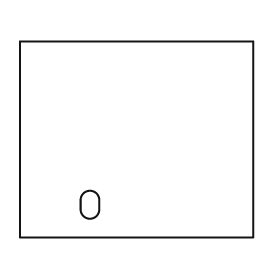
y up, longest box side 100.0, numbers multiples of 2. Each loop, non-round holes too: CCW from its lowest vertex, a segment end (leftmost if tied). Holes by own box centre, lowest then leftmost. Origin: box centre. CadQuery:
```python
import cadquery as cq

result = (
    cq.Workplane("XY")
    .moveTo(-50.0, -42.0)
    .lineTo(50.0, -42.0)
    .lineTo(50.0, 42.0)
    .lineTo(-50.0, 42.0)
    .close()
    .moveTo(-24.0, -30.0)
    .threePointArc((-20.0, -34.0), (-16.0, -30.0))
    .lineTo(-16.0, -26.0)
    .threePointArc((-20.0, -22.0), (-24.0, -26.0))
    .close()
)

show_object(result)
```